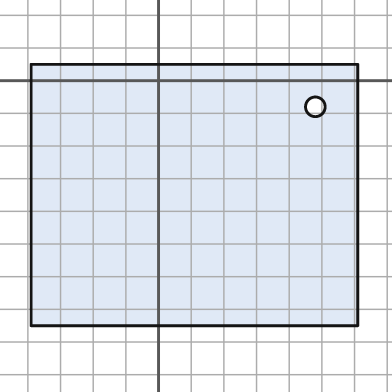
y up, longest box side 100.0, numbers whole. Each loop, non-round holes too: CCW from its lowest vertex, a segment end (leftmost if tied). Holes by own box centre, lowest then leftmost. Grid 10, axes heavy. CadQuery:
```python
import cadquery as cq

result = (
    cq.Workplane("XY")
    .moveTo(-39.0, -75.0)
    .lineTo(61.0, -75.0)
    .lineTo(61.0, 5.0)
    .lineTo(-39.0, 5.0)
    .close()
    .moveTo(48.0, -8.0)
    .circle(3.0)
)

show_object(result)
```